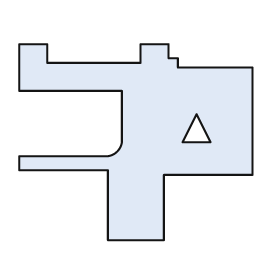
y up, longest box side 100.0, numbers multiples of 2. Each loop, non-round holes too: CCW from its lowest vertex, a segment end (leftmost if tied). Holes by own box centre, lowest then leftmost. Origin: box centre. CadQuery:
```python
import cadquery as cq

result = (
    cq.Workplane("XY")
    .moveTo(-12.0, -42.0)
    .lineTo(12.0, -42.0)
    .lineTo(12.0, -14.0)
    .lineTo(50.0, -14.0)
    .lineTo(50.0, 32.0)
    .lineTo(18.0, 32.0)
    .lineTo(18.0, 36.0)
    .lineTo(14.0, 36.0)
    .lineTo(14.0, 42.0)
    .lineTo(2.0, 42.0)
    .lineTo(2.0, 34.0)
    .lineTo(-38.0, 34.0)
    .lineTo(-38.0, 42.0)
    .lineTo(-50.0, 42.0)
    .lineTo(-50.0, 22.0)
    .lineTo(-6.0, 22.0)
    .lineTo(-6.0, 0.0)
    .threePointArc((-8.0, -4.0), (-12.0, -6.0))
    .lineTo(-50.0, -6.0)
    .lineTo(-50.0, -12.0)
    .lineTo(-12.0, -12.0)
    .close()
    .moveTo(20.0, 0.0)
    .lineTo(32.0, 0.0)
    .lineTo(26.0, 12.0)
    .close()
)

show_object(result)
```